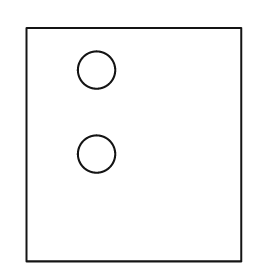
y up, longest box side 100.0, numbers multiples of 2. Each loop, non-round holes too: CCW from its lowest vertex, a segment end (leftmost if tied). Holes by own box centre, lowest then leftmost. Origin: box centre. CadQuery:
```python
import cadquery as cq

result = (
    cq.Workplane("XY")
    .moveTo(-46.0, -50.0)
    .lineTo(46.0, -50.0)
    .lineTo(46.0, 50.0)
    .lineTo(-46.0, 50.0)
    .close()
    .moveTo(-16.0, -4.0)
    .circle(8.0)
    .moveTo(-16.0, 32.0)
    .circle(8.0)
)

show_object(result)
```